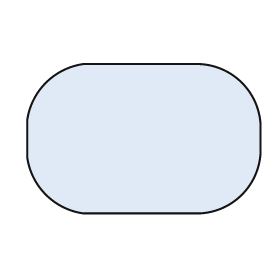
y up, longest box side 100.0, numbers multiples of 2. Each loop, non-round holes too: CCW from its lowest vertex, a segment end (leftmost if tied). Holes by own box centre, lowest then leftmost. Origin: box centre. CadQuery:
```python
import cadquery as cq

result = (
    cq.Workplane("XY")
    .moveTo(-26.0, -32.0)
    .lineTo(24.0, -32.0)
    .threePointArc((42.0, -24.0), (50.0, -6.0))
    .lineTo(50.0, 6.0)
    .threePointArc((42.0, 24.0), (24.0, 32.0))
    .lineTo(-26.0, 32.0)
    .threePointArc((-42.0, 24.0), (-50.0, 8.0))
    .lineTo(-50.0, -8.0)
    .threePointArc((-42.0, -24.0), (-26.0, -32.0))
    .close()
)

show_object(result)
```